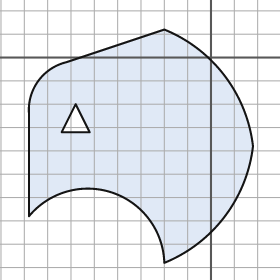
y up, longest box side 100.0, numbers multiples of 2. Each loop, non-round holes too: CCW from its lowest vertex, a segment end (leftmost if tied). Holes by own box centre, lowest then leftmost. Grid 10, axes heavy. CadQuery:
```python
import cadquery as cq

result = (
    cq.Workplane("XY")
    .moveTo(-20.0, -88.0)
    .threePointArc((6.0, -68.0), (18.0, -38.0))
    .threePointArc((6.0, -8.0), (-20.0, 12.0))
    .lineTo(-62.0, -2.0)
    .threePointArc((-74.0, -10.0), (-78.0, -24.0))
    .lineTo(-78.0, -68.0)
    .threePointArc((-42.0, -58.0), (-20.0, -88.0))
    .close()
    .moveTo(-64.0, -32.0)
    .lineTo(-52.0, -32.0)
    .lineTo(-58.0, -20.0)
    .close()
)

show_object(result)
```